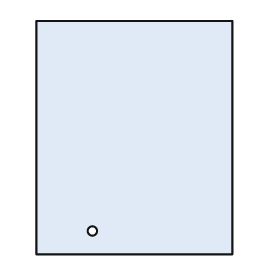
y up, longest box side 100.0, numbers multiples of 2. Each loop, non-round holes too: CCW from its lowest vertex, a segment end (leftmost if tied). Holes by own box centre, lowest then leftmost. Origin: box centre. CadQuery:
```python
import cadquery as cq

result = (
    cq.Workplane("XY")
    .moveTo(-42.0, -50.0)
    .lineTo(42.0, -50.0)
    .lineTo(42.0, 50.0)
    .lineTo(-42.0, 50.0)
    .close()
    .moveTo(-18.0, -40.0)
    .circle(2.0)
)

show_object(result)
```